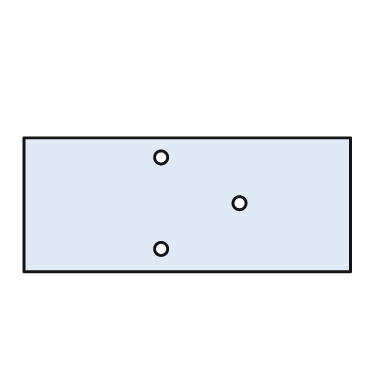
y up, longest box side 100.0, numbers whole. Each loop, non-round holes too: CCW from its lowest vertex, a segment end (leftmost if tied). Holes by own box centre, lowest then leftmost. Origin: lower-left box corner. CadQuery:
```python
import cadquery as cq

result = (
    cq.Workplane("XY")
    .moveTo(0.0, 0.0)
    .lineTo(100.0, 0.0)
    .lineTo(100.0, 41.0)
    .lineTo(0.0, 41.0)
    .close()
    .moveTo(42.0, 7.0)
    .circle(2.0)
    .moveTo(66.0, 21.0)
    .circle(2.0)
    .moveTo(42.0, 35.0)
    .circle(2.0)
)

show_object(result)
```